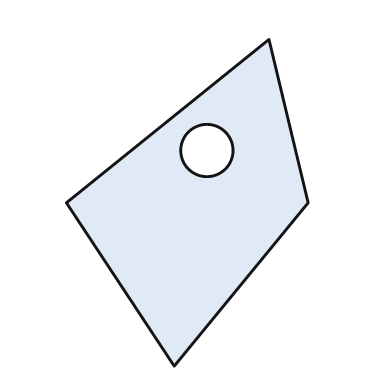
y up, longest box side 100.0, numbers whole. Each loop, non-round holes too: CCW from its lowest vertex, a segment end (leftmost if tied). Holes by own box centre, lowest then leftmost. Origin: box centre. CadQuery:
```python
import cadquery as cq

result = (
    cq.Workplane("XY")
    .moveTo(-4.0, -50.0)
    .lineTo(37.0, 0.0)
    .lineTo(25.0, 50.0)
    .lineTo(-37.0, 0.0)
    .close()
    .moveTo(6.0, 16.0)
    .circle(8.0)
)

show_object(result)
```